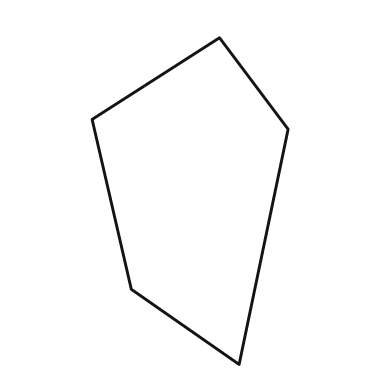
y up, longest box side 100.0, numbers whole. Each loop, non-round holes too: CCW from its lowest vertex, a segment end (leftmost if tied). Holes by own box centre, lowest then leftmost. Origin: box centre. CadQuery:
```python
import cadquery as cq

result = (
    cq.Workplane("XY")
    .moveTo(15.0, -50.0)
    .lineTo(30.0, 22.0)
    .lineTo(9.0, 50.0)
    .lineTo(-30.0, 25.0)
    .lineTo(-18.0, -27.0)
    .close()
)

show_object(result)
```